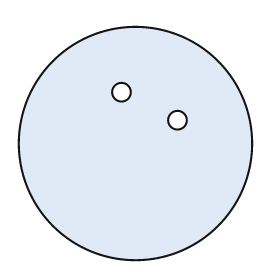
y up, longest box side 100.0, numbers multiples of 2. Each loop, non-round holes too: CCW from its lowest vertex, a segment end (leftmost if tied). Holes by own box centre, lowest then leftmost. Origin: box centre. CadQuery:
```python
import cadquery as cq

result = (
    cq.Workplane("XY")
    .moveTo(0.0, 0.0)
    .circle(50.0)
    .moveTo(18.0, 10.0)
    .circle(4.0)
    .moveTo(-6.0, 22.0)
    .circle(4.0)
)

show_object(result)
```